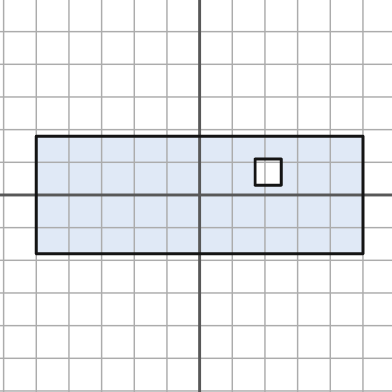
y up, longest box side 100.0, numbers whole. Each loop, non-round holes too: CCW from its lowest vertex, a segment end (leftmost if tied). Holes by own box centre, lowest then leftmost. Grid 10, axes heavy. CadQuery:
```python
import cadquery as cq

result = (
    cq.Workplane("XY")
    .moveTo(-50.0, -18.0)
    .lineTo(50.0, -18.0)
    .lineTo(50.0, 18.0)
    .lineTo(-50.0, 18.0)
    .close()
    .moveTo(17.0, 3.0)
    .lineTo(25.0, 3.0)
    .lineTo(25.0, 11.0)
    .lineTo(17.0, 11.0)
    .close()
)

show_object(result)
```